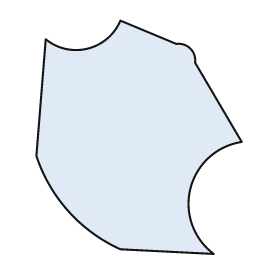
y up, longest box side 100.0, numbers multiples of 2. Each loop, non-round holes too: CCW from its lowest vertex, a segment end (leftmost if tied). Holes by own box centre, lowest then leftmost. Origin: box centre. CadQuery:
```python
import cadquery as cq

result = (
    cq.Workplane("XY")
    .moveTo(32.0, -50.0)
    .threePointArc((22.0, -22.0), (44.0, -2.0))
    .lineTo(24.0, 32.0)
    .threePointArc((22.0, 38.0), (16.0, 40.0))
    .lineTo(-8.0, 50.0)
    .threePointArc((-22.0, 38.0), (-40.0, 42.0))
    .lineTo(-44.0, -8.0)
    .threePointArc((-30.0, -32.0), (-8.0, -48.0))
    .close()
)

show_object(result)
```